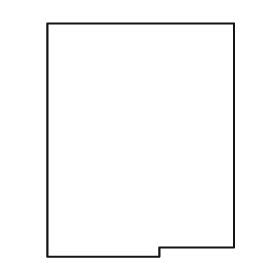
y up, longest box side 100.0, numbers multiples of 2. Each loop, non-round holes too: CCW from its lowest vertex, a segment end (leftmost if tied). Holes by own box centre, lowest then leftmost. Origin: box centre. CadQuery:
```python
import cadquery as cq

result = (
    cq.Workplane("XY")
    .moveTo(-40.0, -50.0)
    .lineTo(8.0, -50.0)
    .lineTo(8.0, -46.0)
    .lineTo(40.0, -46.0)
    .lineTo(40.0, 50.0)
    .lineTo(-40.0, 50.0)
    .close()
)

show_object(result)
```